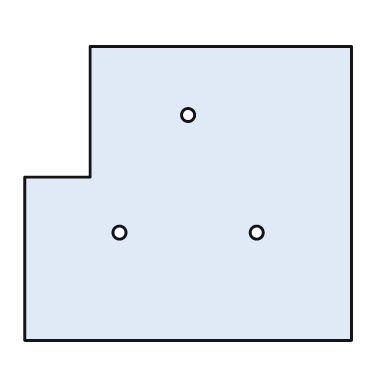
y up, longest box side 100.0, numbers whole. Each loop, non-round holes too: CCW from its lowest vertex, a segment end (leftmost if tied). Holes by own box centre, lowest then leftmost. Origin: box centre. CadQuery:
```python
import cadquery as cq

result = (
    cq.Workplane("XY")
    .moveTo(-50.0, -45.0)
    .lineTo(50.0, -45.0)
    .lineTo(50.0, 45.0)
    .lineTo(-30.0, 45.0)
    .lineTo(-30.0, 5.0)
    .lineTo(-50.0, 5.0)
    .close()
    .moveTo(-21.0, -12.0)
    .circle(2.0)
    .moveTo(21.0, -12.0)
    .circle(2.0)
    .moveTo(0.0, 24.0)
    .circle(2.0)
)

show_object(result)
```